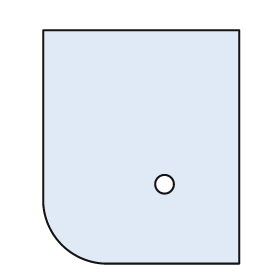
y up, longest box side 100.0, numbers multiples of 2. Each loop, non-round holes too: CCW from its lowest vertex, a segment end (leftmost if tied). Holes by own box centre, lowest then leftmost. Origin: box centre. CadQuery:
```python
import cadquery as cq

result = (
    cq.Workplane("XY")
    .moveTo(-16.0, -50.0)
    .lineTo(42.0, -50.0)
    .lineTo(42.0, 50.0)
    .lineTo(-42.0, 50.0)
    .lineTo(-42.0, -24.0)
    .threePointArc((-34.0, -42.0), (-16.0, -50.0))
    .close()
    .moveTo(10.0, -16.0)
    .circle(4.0)
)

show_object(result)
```